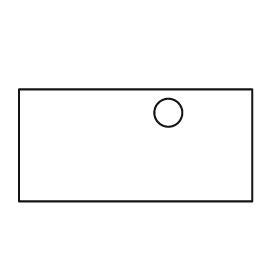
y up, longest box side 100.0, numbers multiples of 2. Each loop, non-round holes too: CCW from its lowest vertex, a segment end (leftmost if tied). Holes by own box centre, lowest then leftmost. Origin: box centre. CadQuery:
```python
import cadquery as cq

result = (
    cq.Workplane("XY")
    .moveTo(-50.0, -24.0)
    .lineTo(50.0, -24.0)
    .lineTo(50.0, 24.0)
    .lineTo(-50.0, 24.0)
    .close()
    .moveTo(14.0, 14.0)
    .circle(6.0)
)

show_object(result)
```